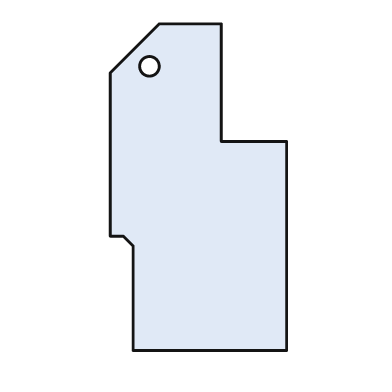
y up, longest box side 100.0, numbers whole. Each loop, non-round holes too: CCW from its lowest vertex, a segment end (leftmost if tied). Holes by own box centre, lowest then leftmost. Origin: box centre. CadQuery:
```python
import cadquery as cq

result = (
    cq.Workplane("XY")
    .moveTo(-20.0, -50.0)
    .lineTo(27.0, -50.0)
    .lineTo(27.0, 14.0)
    .lineTo(7.0, 14.0)
    .lineTo(7.0, 50.0)
    .lineTo(-12.0, 50.0)
    .lineTo(-27.0, 35.0)
    .lineTo(-27.0, -15.0)
    .lineTo(-23.0, -15.0)
    .lineTo(-20.0, -18.0)
    .close()
    .moveTo(-15.0, 37.0)
    .circle(3.0)
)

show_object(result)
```